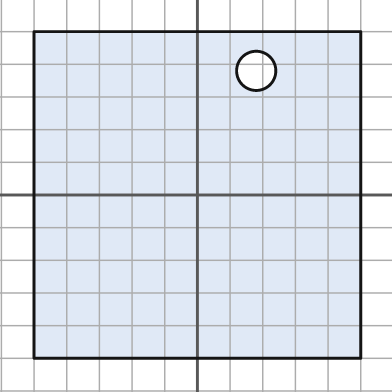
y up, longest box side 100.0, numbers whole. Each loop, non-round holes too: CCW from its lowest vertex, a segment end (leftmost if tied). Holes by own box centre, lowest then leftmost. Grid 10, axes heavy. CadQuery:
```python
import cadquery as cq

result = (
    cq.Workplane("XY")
    .moveTo(-50.0, -50.0)
    .lineTo(50.0, -50.0)
    .lineTo(50.0, 50.0)
    .lineTo(-50.0, 50.0)
    .close()
    .moveTo(18.0, 38.0)
    .circle(6.0)
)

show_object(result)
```